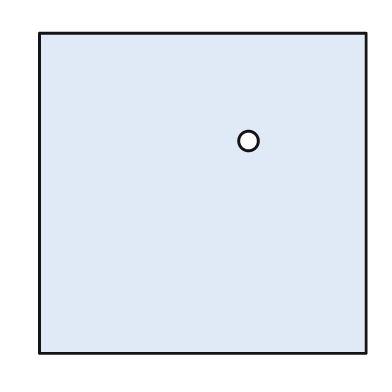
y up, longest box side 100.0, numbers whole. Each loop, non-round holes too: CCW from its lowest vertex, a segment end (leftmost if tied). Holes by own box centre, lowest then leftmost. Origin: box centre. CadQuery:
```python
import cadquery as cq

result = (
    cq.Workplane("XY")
    .moveTo(-50.0, -49.0)
    .lineTo(50.0, -49.0)
    .lineTo(50.0, 49.0)
    .lineTo(-50.0, 49.0)
    .close()
    .moveTo(14.0, 16.0)
    .circle(3.0)
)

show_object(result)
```